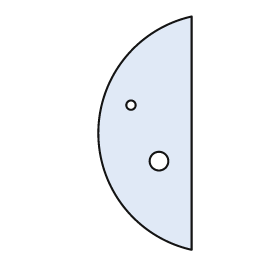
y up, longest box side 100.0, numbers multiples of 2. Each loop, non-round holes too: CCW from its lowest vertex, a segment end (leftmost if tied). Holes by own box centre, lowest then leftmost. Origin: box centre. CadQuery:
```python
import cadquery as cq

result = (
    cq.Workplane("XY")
    .moveTo(20.0, -50.0)
    .lineTo(20.0, 50.0)
    .threePointArc((-20.0, 0.0), (20.0, -50.0))
    .close()
    .moveTo(6.0, -12.0)
    .circle(4.0)
    .moveTo(-6.0, 12.0)
    .circle(2.0)
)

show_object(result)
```